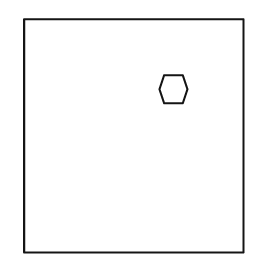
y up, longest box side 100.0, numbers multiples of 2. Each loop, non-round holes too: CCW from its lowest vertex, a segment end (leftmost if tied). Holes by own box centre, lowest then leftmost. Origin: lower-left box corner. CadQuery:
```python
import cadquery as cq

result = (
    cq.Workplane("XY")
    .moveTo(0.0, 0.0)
    .lineTo(94.0, 0.0)
    .lineTo(94.0, 100.0)
    .lineTo(0.0, 100.0)
    .close()
    .moveTo(60.0, 64.0)
    .lineTo(68.0, 64.0)
    .lineTo(70.0, 70.0)
    .lineTo(68.0, 76.0)
    .lineTo(60.0, 76.0)
    .lineTo(58.0, 70.0)
    .close()
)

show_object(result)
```